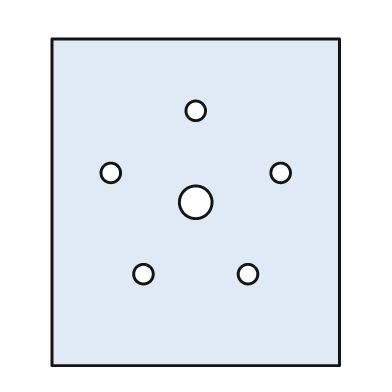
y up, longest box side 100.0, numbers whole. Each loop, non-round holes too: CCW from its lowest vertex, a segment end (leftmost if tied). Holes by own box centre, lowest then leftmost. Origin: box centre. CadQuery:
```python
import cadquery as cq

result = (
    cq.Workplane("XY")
    .moveTo(-44.0, -50.0)
    .lineTo(44.0, -50.0)
    .lineTo(44.0, 50.0)
    .lineTo(-44.0, 50.0)
    .close()
    .moveTo(-16.0, -22.0)
    .circle(3.0)
    .moveTo(16.0, -22.0)
    .circle(3.0)
    .moveTo(0.0, 0.0)
    .circle(5.0)
    .moveTo(-26.0, 9.0)
    .circle(3.0)
    .moveTo(26.0, 9.0)
    .circle(3.0)
    .moveTo(0.0, 28.0)
    .circle(3.0)
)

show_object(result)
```